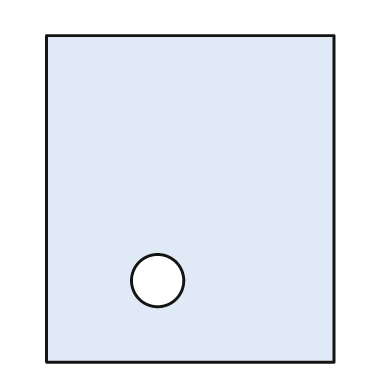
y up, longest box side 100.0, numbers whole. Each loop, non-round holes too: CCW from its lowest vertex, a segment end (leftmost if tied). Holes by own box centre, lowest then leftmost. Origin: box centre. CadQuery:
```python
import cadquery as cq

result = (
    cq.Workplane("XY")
    .moveTo(-44.0, -50.0)
    .lineTo(44.0, -50.0)
    .lineTo(44.0, 50.0)
    .lineTo(-44.0, 50.0)
    .close()
    .moveTo(-10.0, -25.0)
    .circle(8.0)
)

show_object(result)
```